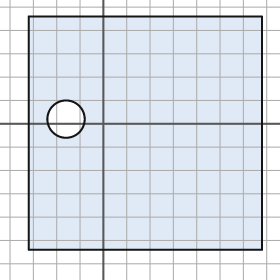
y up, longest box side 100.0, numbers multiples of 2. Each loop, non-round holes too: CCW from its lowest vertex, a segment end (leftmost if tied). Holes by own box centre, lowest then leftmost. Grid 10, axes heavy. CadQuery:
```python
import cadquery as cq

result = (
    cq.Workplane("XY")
    .moveTo(-32.0, -54.0)
    .lineTo(68.0, -54.0)
    .lineTo(68.0, 46.0)
    .lineTo(-32.0, 46.0)
    .close()
    .moveTo(-16.0, 2.0)
    .circle(8.0)
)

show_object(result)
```